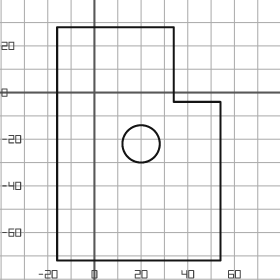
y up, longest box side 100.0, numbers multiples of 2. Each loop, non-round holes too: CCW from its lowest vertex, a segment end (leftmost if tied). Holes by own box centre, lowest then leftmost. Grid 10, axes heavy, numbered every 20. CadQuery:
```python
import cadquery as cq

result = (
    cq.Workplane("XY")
    .moveTo(-16.0, -72.0)
    .lineTo(54.0, -72.0)
    .lineTo(54.0, -4.0)
    .lineTo(34.0, -4.0)
    .lineTo(34.0, 28.0)
    .lineTo(-16.0, 28.0)
    .close()
    .moveTo(20.0, -22.0)
    .circle(8.0)
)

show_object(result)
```